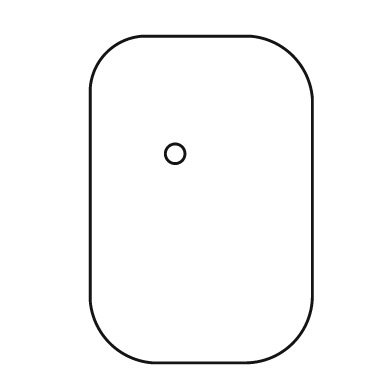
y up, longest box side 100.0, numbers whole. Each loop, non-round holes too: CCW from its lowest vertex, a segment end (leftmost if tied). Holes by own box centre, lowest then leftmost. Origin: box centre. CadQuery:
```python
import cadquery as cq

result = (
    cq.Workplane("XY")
    .moveTo(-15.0, -50.0)
    .lineTo(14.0, -50.0)
    .threePointArc((28.0, -44.0), (34.0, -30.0))
    .lineTo(34.0, 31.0)
    .threePointArc((28.0, 44.0), (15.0, 50.0))
    .lineTo(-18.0, 50.0)
    .threePointArc((-29.0, 45.0), (-34.0, 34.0))
    .lineTo(-34.0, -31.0)
    .threePointArc((-28.0, -44.0), (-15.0, -50.0))
    .close()
    .moveTo(-8.0, 14.0)
    .circle(3.0)
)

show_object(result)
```